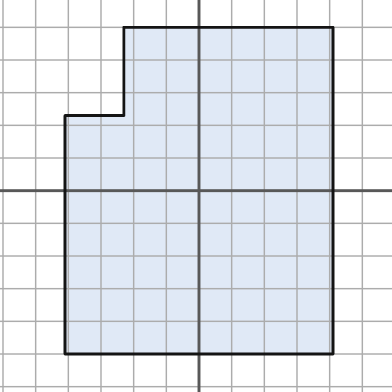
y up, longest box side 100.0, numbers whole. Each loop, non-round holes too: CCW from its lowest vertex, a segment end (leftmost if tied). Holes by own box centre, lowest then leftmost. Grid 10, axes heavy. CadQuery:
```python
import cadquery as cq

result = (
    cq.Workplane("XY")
    .moveTo(-41.0, -50.0)
    .lineTo(41.0, -50.0)
    .lineTo(41.0, 50.0)
    .lineTo(-23.0, 50.0)
    .lineTo(-23.0, 23.0)
    .lineTo(-41.0, 23.0)
    .close()
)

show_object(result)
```